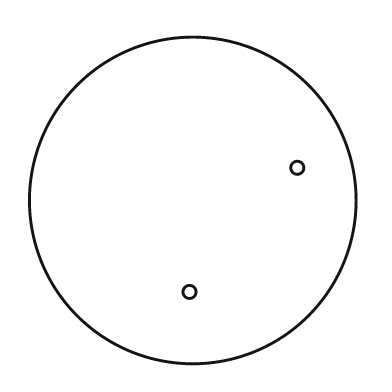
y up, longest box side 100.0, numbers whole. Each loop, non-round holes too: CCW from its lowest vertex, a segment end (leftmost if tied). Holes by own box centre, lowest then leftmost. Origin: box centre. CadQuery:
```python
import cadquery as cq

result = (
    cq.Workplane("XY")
    .moveTo(0.0, 0.0)
    .circle(50.0)
    .moveTo(-1.0, -28.0)
    .circle(2.0)
    .moveTo(32.0, 10.0)
    .circle(2.0)
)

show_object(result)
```